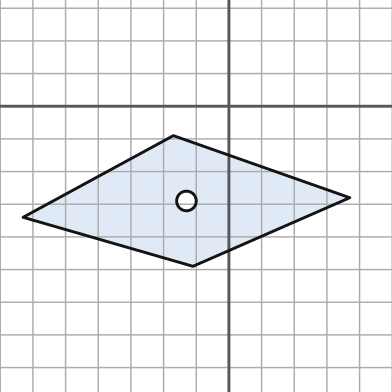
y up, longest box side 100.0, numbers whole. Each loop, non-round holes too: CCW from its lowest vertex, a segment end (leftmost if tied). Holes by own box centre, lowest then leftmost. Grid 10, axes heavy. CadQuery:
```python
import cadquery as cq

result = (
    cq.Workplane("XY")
    .moveTo(-11.0, -49.0)
    .lineTo(37.0, -28.0)
    .lineTo(-17.0, -9.0)
    .lineTo(-63.0, -34.0)
    .close()
    .moveTo(-13.0, -29.0)
    .circle(3.0)
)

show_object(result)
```